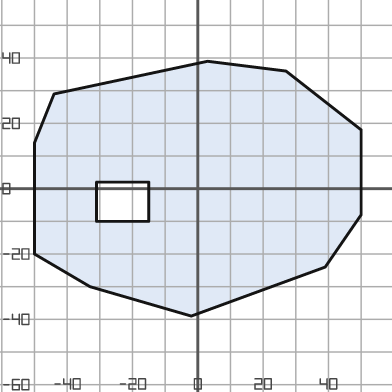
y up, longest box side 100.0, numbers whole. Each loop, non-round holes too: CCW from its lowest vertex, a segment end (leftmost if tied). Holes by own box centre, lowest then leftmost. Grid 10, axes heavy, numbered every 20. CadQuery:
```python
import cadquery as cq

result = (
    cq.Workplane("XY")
    .moveTo(-2.0, -39.0)
    .lineTo(39.0, -24.0)
    .lineTo(50.0, -8.0)
    .lineTo(50.0, 18.0)
    .lineTo(27.0, 36.0)
    .lineTo(3.0, 39.0)
    .lineTo(-44.0, 29.0)
    .lineTo(-50.0, 14.0)
    .lineTo(-50.0, -20.0)
    .lineTo(-33.0, -30.0)
    .close()
    .moveTo(-31.0, -10.0)
    .lineTo(-15.0, -10.0)
    .lineTo(-15.0, 2.0)
    .lineTo(-31.0, 2.0)
    .close()
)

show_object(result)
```